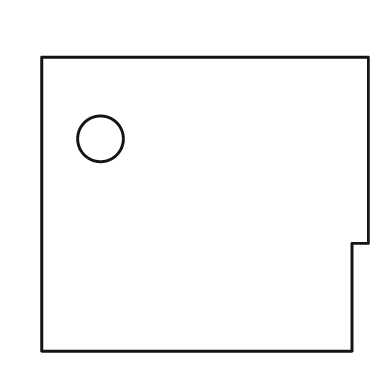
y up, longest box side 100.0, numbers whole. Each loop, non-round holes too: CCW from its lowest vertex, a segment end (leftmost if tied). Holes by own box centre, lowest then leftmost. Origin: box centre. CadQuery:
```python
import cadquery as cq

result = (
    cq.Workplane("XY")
    .moveTo(-50.0, -45.0)
    .lineTo(45.0, -45.0)
    .lineTo(45.0, -12.0)
    .lineTo(50.0, -12.0)
    .lineTo(50.0, 45.0)
    .lineTo(-50.0, 45.0)
    .close()
    .moveTo(-32.0, 20.0)
    .circle(7.0)
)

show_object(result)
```